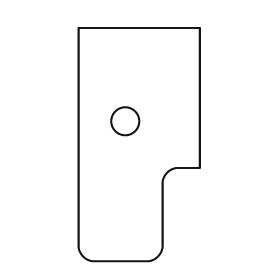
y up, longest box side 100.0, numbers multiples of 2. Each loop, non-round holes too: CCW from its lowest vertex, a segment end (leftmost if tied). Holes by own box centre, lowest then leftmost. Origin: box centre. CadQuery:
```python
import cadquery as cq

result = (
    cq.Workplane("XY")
    .moveTo(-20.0, -50.0)
    .lineTo(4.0, -50.0)
    .threePointArc((8.0, -48.0), (10.0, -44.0))
    .lineTo(10.0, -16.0)
    .threePointArc((12.0, -12.0), (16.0, -10.0))
    .lineTo(26.0, -10.0)
    .lineTo(26.0, 50.0)
    .lineTo(-26.0, 50.0)
    .lineTo(-26.0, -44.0)
    .threePointArc((-24.0, -48.0), (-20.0, -50.0))
    .close()
    .moveTo(-6.0, 10.0)
    .circle(6.0)
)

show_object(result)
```